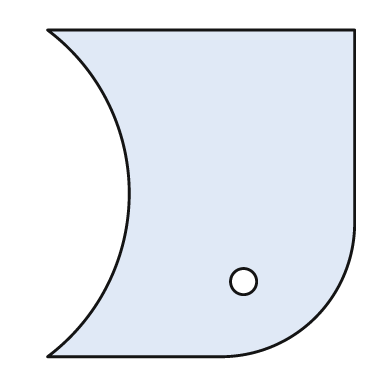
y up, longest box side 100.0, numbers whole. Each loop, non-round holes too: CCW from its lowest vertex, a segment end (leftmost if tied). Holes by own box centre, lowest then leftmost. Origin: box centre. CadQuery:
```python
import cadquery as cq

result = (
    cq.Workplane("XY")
    .moveTo(-47.0, -50.0)
    .lineTo(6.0, -50.0)
    .threePointArc((35.0, -38.0), (47.0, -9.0))
    .lineTo(47.0, 50.0)
    .lineTo(-47.0, 50.0)
    .threePointArc((-22.0, 0.0), (-47.0, -50.0))
    .close()
    .moveTo(13.0, -27.0)
    .circle(4.0)
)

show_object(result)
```